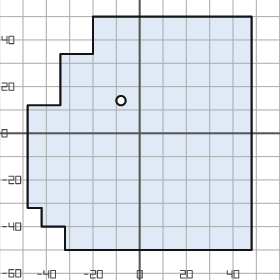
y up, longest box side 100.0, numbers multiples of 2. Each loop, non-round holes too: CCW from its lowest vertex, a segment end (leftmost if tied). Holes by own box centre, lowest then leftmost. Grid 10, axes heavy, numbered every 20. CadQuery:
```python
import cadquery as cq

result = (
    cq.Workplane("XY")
    .moveTo(-32.0, -50.0)
    .lineTo(48.0, -50.0)
    .lineTo(48.0, 50.0)
    .lineTo(-20.0, 50.0)
    .lineTo(-20.0, 34.0)
    .lineTo(-34.0, 34.0)
    .lineTo(-34.0, 12.0)
    .lineTo(-48.0, 12.0)
    .lineTo(-48.0, -32.0)
    .lineTo(-42.0, -32.0)
    .lineTo(-42.0, -40.0)
    .lineTo(-32.0, -40.0)
    .close()
    .moveTo(-8.0, 14.0)
    .circle(2.0)
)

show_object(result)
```